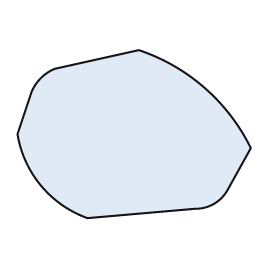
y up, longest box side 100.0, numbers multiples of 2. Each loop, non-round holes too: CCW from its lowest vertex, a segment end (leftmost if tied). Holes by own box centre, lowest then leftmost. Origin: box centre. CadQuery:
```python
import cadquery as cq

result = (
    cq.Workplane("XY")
    .moveTo(-20.0, -36.0)
    .lineTo(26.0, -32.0)
    .threePointArc((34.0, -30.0), (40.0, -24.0))
    .lineTo(50.0, -6.0)
    .threePointArc((30.0, 20.0), (2.0, 36.0))
    .lineTo(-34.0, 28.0)
    .threePointArc((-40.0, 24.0), (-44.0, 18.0))
    .lineTo(-50.0, 0.0)
    .threePointArc((-40.0, -22.0), (-20.0, -36.0))
    .close()
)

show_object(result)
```